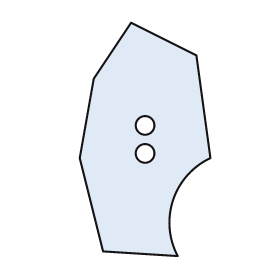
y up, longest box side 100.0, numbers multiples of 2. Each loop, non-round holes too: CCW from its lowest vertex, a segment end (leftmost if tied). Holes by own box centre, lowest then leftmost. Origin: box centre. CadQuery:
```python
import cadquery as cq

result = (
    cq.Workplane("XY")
    .moveTo(14.0, -50.0)
    .threePointArc((12.0, -26.0), (28.0, -8.0))
    .lineTo(22.0, 36.0)
    .lineTo(-6.0, 50.0)
    .lineTo(-22.0, 26.0)
    .lineTo(-28.0, -8.0)
    .lineTo(-18.0, -48.0)
    .close()
    .moveTo(0.0, -6.0)
    .circle(4.0)
    .moveTo(0.0, 6.0)
    .circle(4.0)
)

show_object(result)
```